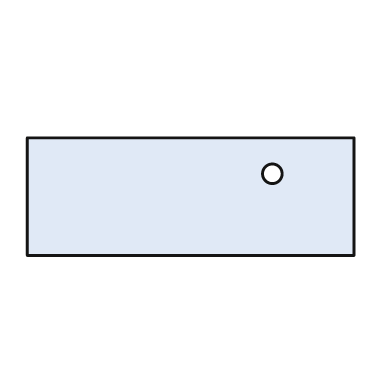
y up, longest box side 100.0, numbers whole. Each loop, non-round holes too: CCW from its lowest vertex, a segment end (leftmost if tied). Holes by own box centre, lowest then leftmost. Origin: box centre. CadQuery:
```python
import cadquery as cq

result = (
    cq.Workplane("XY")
    .moveTo(-50.0, -18.0)
    .lineTo(50.0, -18.0)
    .lineTo(50.0, 18.0)
    .lineTo(-50.0, 18.0)
    .close()
    .moveTo(25.0, 7.0)
    .circle(3.0)
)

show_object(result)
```